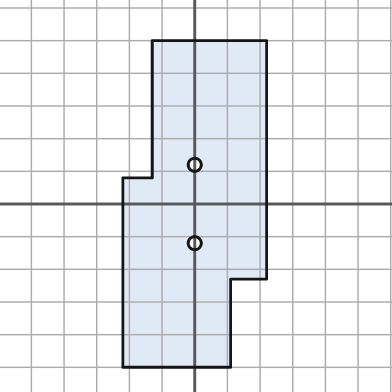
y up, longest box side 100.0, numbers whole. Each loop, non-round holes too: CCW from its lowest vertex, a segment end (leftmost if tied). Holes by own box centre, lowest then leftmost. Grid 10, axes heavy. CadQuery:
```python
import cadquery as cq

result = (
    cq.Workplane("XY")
    .moveTo(-22.0, -50.0)
    .lineTo(11.0, -50.0)
    .lineTo(11.0, -23.0)
    .lineTo(22.0, -23.0)
    .lineTo(22.0, 50.0)
    .lineTo(-13.0, 50.0)
    .lineTo(-13.0, 8.0)
    .lineTo(-22.0, 8.0)
    .close()
    .moveTo(0.0, -12.0)
    .circle(2.0)
    .moveTo(0.0, 12.0)
    .circle(2.0)
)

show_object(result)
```